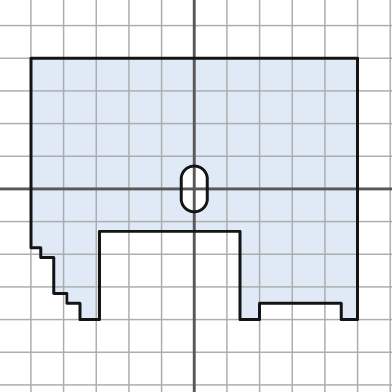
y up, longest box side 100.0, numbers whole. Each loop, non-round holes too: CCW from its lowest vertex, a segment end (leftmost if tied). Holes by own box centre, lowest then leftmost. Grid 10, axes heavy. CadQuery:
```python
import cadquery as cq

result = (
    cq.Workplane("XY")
    .moveTo(-35.0, -40.0)
    .lineTo(-29.0, -40.0)
    .lineTo(-29.0, -13.0)
    .lineTo(14.0, -13.0)
    .lineTo(14.0, -40.0)
    .lineTo(20.0, -40.0)
    .lineTo(20.0, -35.0)
    .lineTo(45.0, -35.0)
    .lineTo(45.0, -40.0)
    .lineTo(50.0, -40.0)
    .lineTo(50.0, 40.0)
    .lineTo(-50.0, 40.0)
    .lineTo(-50.0, -18.0)
    .lineTo(-47.0, -18.0)
    .lineTo(-47.0, -21.0)
    .lineTo(-43.0, -21.0)
    .lineTo(-43.0, -32.0)
    .lineTo(-39.0, -32.0)
    .lineTo(-39.0, -35.0)
    .lineTo(-35.0, -35.0)
    .close()
    .moveTo(-4.0, -3.0)
    .threePointArc((0.0, -7.0), (4.0, -3.0))
    .lineTo(4.0, 3.0)
    .threePointArc((0.0, 7.0), (-4.0, 3.0))
    .close()
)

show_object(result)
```